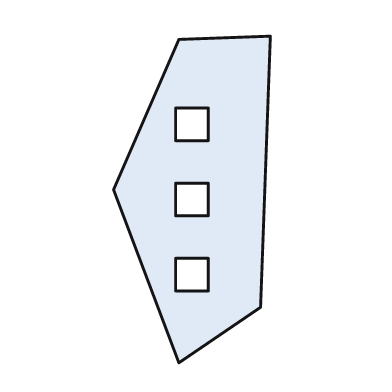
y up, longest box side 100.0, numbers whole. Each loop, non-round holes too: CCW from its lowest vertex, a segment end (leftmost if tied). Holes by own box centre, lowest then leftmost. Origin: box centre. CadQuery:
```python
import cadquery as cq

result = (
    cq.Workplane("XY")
    .moveTo(-4.0, -50.0)
    .lineTo(21.0, -33.0)
    .lineTo(24.0, 50.0)
    .lineTo(-4.0, 49.0)
    .lineTo(-24.0, 3.0)
    .close()
    .moveTo(-5.0, -28.0)
    .lineTo(5.0, -28.0)
    .lineTo(5.0, -18.0)
    .lineTo(-5.0, -18.0)
    .close()
    .moveTo(-5.0, -5.0)
    .lineTo(5.0, -5.0)
    .lineTo(5.0, 5.0)
    .lineTo(-5.0, 5.0)
    .close()
    .moveTo(-5.0, 18.0)
    .lineTo(5.0, 18.0)
    .lineTo(5.0, 28.0)
    .lineTo(-5.0, 28.0)
    .close()
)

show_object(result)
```